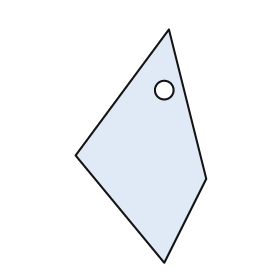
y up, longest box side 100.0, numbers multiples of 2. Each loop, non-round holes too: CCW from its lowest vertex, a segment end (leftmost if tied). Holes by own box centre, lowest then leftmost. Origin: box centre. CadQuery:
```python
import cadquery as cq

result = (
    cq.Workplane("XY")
    .moveTo(10.0, -50.0)
    .lineTo(28.0, -14.0)
    .lineTo(12.0, 50.0)
    .lineTo(-28.0, -4.0)
    .close()
    .moveTo(10.0, 24.0)
    .circle(4.0)
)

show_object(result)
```